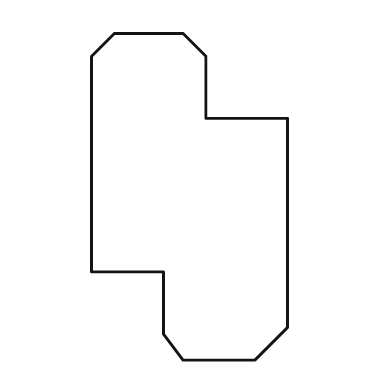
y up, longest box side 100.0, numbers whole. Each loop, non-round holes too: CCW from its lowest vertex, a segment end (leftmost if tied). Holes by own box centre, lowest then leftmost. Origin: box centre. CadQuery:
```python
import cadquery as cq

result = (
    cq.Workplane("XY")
    .moveTo(-2.0, -50.0)
    .lineTo(20.0, -50.0)
    .lineTo(30.0, -40.0)
    .lineTo(30.0, 24.0)
    .lineTo(5.0, 24.0)
    .lineTo(5.0, 43.0)
    .lineTo(-2.0, 50.0)
    .lineTo(-23.0, 50.0)
    .lineTo(-30.0, 43.0)
    .lineTo(-30.0, -23.0)
    .lineTo(-8.0, -23.0)
    .lineTo(-8.0, -42.0)
    .close()
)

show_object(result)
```